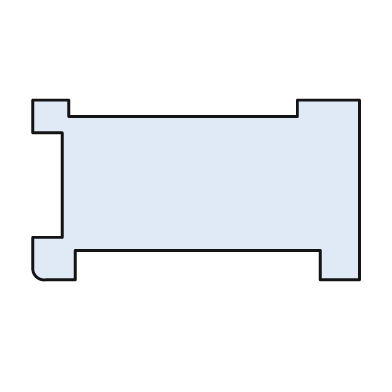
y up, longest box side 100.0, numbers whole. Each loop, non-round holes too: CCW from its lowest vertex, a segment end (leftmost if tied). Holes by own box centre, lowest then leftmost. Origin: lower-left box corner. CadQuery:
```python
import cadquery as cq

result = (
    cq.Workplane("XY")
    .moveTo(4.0, 0.0)
    .lineTo(13.0, 0.0)
    .lineTo(13.0, 9.0)
    .lineTo(88.0, 9.0)
    .lineTo(88.0, 0.0)
    .lineTo(100.0, 0.0)
    .lineTo(100.0, 55.0)
    .lineTo(81.0, 55.0)
    .lineTo(81.0, 50.0)
    .lineTo(11.0, 50.0)
    .lineTo(11.0, 55.0)
    .lineTo(0.0, 55.0)
    .lineTo(0.0, 45.0)
    .lineTo(9.0, 45.0)
    .lineTo(9.0, 13.0)
    .lineTo(0.0, 13.0)
    .lineTo(0.0, 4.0)
    .threePointArc((1.0, 1.0), (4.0, 0.0))
    .close()
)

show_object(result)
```